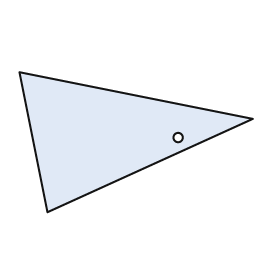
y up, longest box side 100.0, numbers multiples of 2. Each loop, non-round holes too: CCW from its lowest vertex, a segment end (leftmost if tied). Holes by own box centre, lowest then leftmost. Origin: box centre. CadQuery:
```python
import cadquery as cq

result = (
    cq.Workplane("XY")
    .moveTo(-38.0, -30.0)
    .lineTo(50.0, 10.0)
    .lineTo(-50.0, 30.0)
    .close()
    .moveTo(18.0, 2.0)
    .circle(2.0)
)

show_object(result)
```